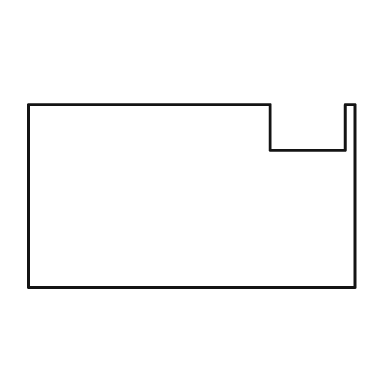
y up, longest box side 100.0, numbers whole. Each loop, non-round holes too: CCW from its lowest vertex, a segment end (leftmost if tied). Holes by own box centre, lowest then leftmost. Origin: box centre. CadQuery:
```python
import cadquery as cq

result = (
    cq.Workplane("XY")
    .moveTo(-50.0, -28.0)
    .lineTo(50.0, -28.0)
    .lineTo(50.0, 28.0)
    .lineTo(47.0, 28.0)
    .lineTo(47.0, 14.0)
    .lineTo(24.0, 14.0)
    .lineTo(24.0, 28.0)
    .lineTo(-50.0, 28.0)
    .close()
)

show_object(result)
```